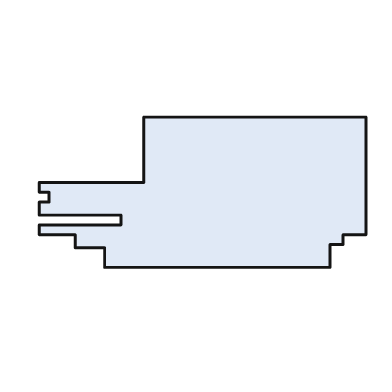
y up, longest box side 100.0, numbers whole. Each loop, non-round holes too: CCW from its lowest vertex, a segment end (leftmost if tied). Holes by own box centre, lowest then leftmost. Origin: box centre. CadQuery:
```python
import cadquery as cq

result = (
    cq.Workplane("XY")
    .moveTo(-30.0, -23.0)
    .lineTo(39.0, -23.0)
    .lineTo(39.0, -16.0)
    .lineTo(43.0, -16.0)
    .lineTo(43.0, -13.0)
    .lineTo(50.0, -13.0)
    .lineTo(50.0, 23.0)
    .lineTo(-18.0, 23.0)
    .lineTo(-18.0, 3.0)
    .lineTo(-50.0, 3.0)
    .lineTo(-50.0, 0.0)
    .lineTo(-47.0, 0.0)
    .lineTo(-47.0, -3.0)
    .lineTo(-50.0, -3.0)
    .lineTo(-50.0, -7.0)
    .lineTo(-25.0, -7.0)
    .lineTo(-25.0, -10.0)
    .lineTo(-50.0, -10.0)
    .lineTo(-50.0, -13.0)
    .lineTo(-39.0, -13.0)
    .lineTo(-39.0, -17.0)
    .lineTo(-30.0, -17.0)
    .close()
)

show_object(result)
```